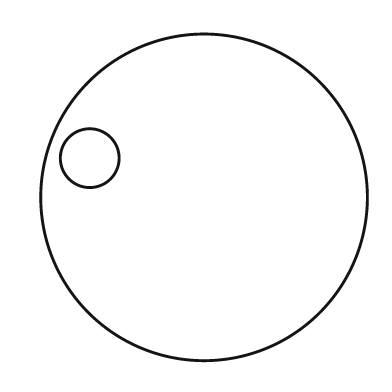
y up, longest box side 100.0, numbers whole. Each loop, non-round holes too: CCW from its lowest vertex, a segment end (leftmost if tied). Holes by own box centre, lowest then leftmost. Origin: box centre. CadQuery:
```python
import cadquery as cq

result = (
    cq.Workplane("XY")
    .moveTo(0.0, 0.0)
    .circle(50.0)
    .moveTo(-35.0, 12.0)
    .circle(9.0)
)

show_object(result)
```